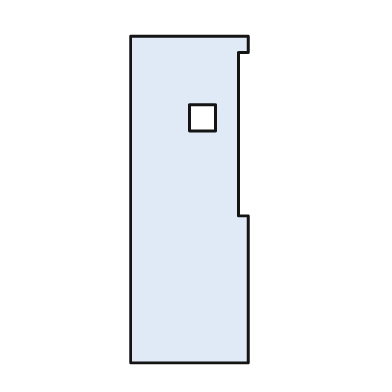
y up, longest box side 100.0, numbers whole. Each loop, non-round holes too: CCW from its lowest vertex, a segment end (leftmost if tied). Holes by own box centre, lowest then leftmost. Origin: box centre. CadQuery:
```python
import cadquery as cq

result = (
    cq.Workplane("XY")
    .moveTo(-18.0, -50.0)
    .lineTo(18.0, -50.0)
    .lineTo(18.0, -5.0)
    .lineTo(15.0, -5.0)
    .lineTo(15.0, 45.0)
    .lineTo(18.0, 45.0)
    .lineTo(18.0, 50.0)
    .lineTo(-18.0, 50.0)
    .close()
    .moveTo(0.0, 21.0)
    .lineTo(8.0, 21.0)
    .lineTo(8.0, 29.0)
    .lineTo(0.0, 29.0)
    .close()
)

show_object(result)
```